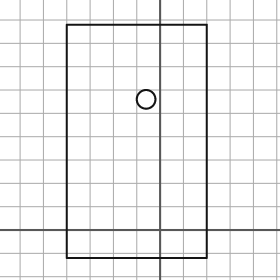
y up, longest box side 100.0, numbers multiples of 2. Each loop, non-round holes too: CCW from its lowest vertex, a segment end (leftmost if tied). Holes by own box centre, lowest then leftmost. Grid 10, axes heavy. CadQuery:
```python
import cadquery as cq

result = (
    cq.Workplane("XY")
    .moveTo(-40.0, -12.0)
    .lineTo(20.0, -12.0)
    .lineTo(20.0, 88.0)
    .lineTo(-40.0, 88.0)
    .close()
    .moveTo(-6.0, 56.0)
    .circle(4.0)
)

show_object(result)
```